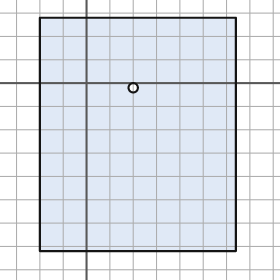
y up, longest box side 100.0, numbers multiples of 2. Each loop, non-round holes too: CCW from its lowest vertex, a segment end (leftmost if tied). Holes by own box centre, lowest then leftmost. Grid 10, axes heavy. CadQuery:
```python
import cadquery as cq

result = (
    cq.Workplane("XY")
    .moveTo(-20.0, -72.0)
    .lineTo(64.0, -72.0)
    .lineTo(64.0, 28.0)
    .lineTo(-20.0, 28.0)
    .close()
    .moveTo(20.0, -2.0)
    .circle(2.0)
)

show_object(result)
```